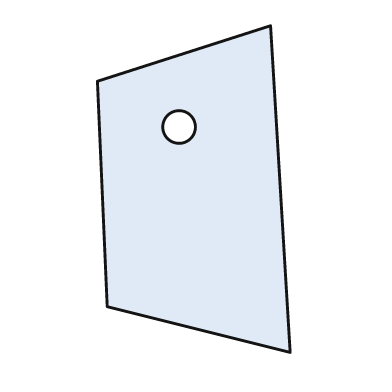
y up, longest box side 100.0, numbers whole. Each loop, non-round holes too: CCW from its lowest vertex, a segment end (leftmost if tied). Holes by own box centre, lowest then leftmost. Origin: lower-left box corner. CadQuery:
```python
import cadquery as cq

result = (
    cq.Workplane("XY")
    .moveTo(59.0, 0.0)
    .lineTo(53.0, 100.0)
    .lineTo(0.0, 83.0)
    .lineTo(3.0, 14.0)
    .close()
    .moveTo(25.0, 69.0)
    .circle(5.0)
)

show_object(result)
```